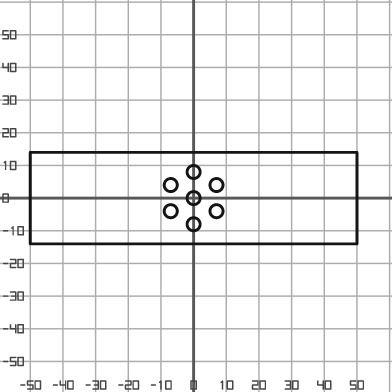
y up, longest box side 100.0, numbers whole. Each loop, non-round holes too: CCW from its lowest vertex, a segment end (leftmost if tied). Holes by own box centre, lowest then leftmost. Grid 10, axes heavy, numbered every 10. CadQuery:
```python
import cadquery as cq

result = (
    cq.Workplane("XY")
    .moveTo(-50.0, -14.0)
    .lineTo(50.0, -14.0)
    .lineTo(50.0, 14.0)
    .lineTo(-50.0, 14.0)
    .close()
    .moveTo(0.0, -8.0)
    .circle(2.0)
    .moveTo(-7.0, -4.0)
    .circle(2.0)
    .moveTo(7.0, -4.0)
    .circle(2.0)
    .moveTo(0.0, 0.0)
    .circle(2.0)
    .moveTo(-7.0, 4.0)
    .circle(2.0)
    .moveTo(7.0, 4.0)
    .circle(2.0)
    .moveTo(0.0, 8.0)
    .circle(2.0)
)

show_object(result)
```